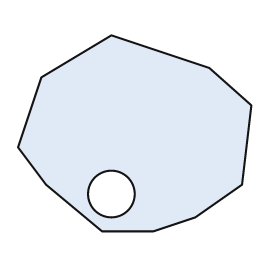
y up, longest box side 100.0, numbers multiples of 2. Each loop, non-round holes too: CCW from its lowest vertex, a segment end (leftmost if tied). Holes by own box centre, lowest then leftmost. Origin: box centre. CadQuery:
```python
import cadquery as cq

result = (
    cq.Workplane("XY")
    .moveTo(-14.0, -42.0)
    .lineTo(8.0, -42.0)
    .lineTo(26.0, -36.0)
    .lineTo(46.0, -22.0)
    .lineTo(50.0, 12.0)
    .lineTo(32.0, 28.0)
    .lineTo(-10.0, 42.0)
    .lineTo(-40.0, 24.0)
    .lineTo(-50.0, -6.0)
    .lineTo(-38.0, -22.0)
    .close()
    .moveTo(-10.0, -26.0)
    .circle(10.0)
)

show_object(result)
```